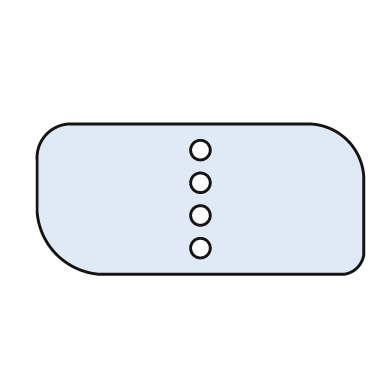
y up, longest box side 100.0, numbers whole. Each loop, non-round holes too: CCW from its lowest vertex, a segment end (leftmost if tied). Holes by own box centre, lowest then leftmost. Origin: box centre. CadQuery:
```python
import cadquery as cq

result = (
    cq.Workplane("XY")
    .moveTo(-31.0, -23.0)
    .lineTo(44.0, -23.0)
    .threePointArc((48.0, -21.0), (50.0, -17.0))
    .lineTo(50.0, 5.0)
    .threePointArc((45.0, 18.0), (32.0, 23.0))
    .lineTo(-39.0, 23.0)
    .threePointArc((-47.0, 20.0), (-50.0, 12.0))
    .lineTo(-50.0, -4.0)
    .threePointArc((-44.0, -17.0), (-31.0, -23.0))
    .close()
    .moveTo(0.0, -15.0)
    .circle(3.0)
    .moveTo(0.0, -5.0)
    .circle(3.0)
    .moveTo(0.0, 5.0)
    .circle(3.0)
    .moveTo(0.0, 15.0)
    .circle(3.0)
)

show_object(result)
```